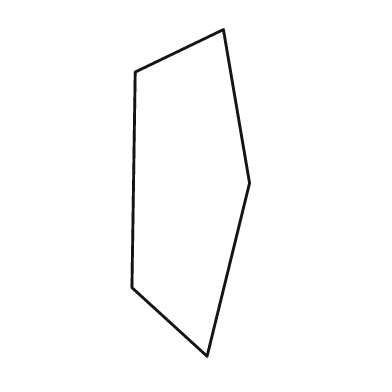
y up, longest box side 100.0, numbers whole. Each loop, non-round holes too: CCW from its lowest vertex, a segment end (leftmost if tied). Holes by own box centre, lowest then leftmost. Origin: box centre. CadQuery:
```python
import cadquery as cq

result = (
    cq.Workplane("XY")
    .moveTo(5.0, -50.0)
    .lineTo(18.0, 3.0)
    .lineTo(10.0, 50.0)
    .lineTo(-17.0, 37.0)
    .lineTo(-18.0, -29.0)
    .close()
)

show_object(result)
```